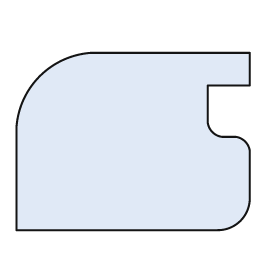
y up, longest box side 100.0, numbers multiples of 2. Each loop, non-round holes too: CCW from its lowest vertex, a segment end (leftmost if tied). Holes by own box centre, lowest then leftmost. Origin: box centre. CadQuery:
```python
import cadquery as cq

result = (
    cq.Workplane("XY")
    .moveTo(-50.0, -38.0)
    .lineTo(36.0, -38.0)
    .threePointArc((46.0, -34.0), (50.0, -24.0))
    .lineTo(50.0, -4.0)
    .threePointArc((48.0, 0.0), (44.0, 2.0))
    .lineTo(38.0, 2.0)
    .threePointArc((34.0, 4.0), (32.0, 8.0))
    .lineTo(32.0, 24.0)
    .lineTo(50.0, 24.0)
    .lineTo(50.0, 38.0)
    .lineTo(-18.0, 38.0)
    .threePointArc((-40.0, 28.0), (-50.0, 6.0))
    .close()
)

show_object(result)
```